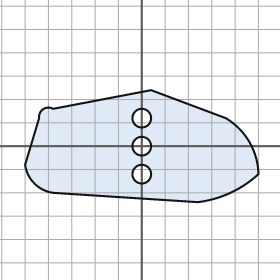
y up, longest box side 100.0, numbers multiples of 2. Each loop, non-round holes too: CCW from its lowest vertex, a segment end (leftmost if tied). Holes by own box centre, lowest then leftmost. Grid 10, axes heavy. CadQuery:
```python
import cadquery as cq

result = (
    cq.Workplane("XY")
    .moveTo(24.0, -24.0)
    .threePointArc((38.0, -20.0), (50.0, -12.0))
    .threePointArc((46.0, 2.0), (36.0, 12.0))
    .lineTo(4.0, 24.0)
    .lineTo(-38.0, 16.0)
    .threePointArc((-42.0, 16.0), (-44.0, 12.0))
    .lineTo(-50.0, -8.0)
    .threePointArc((-46.0, -16.0), (-38.0, -20.0))
    .close()
    .moveTo(0.0, -12.0)
    .circle(4.0)
    .moveTo(0.0, 0.0)
    .circle(4.0)
    .moveTo(0.0, 12.0)
    .circle(4.0)
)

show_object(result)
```